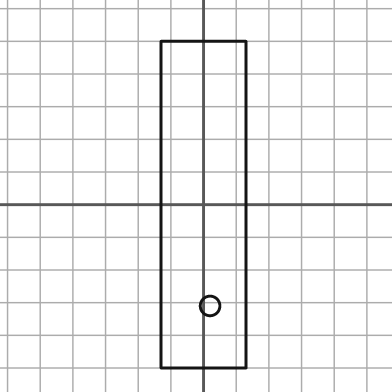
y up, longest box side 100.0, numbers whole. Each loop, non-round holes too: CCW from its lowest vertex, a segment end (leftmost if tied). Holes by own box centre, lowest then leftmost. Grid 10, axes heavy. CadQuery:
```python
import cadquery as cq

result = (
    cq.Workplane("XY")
    .moveTo(-13.0, -50.0)
    .lineTo(13.0, -50.0)
    .lineTo(13.0, 50.0)
    .lineTo(-13.0, 50.0)
    .close()
    .moveTo(2.0, -31.0)
    .circle(3.0)
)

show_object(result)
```